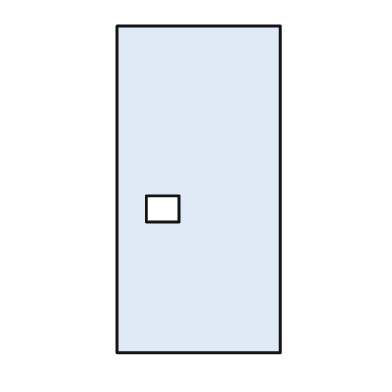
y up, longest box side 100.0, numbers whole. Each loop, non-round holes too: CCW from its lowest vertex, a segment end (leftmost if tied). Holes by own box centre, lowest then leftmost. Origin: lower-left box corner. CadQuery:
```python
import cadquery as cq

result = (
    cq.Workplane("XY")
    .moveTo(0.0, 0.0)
    .lineTo(50.0, 0.0)
    .lineTo(50.0, 100.0)
    .lineTo(0.0, 100.0)
    .close()
    .moveTo(9.0, 40.0)
    .lineTo(19.0, 40.0)
    .lineTo(19.0, 48.0)
    .lineTo(9.0, 48.0)
    .close()
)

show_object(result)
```